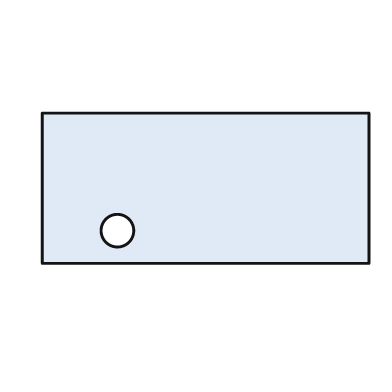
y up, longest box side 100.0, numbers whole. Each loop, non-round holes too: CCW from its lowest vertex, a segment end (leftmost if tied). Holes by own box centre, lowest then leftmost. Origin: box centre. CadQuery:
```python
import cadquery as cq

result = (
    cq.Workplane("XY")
    .moveTo(-50.0, -23.0)
    .lineTo(50.0, -23.0)
    .lineTo(50.0, 23.0)
    .lineTo(-50.0, 23.0)
    .close()
    .moveTo(-27.0, -13.0)
    .circle(5.0)
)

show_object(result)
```